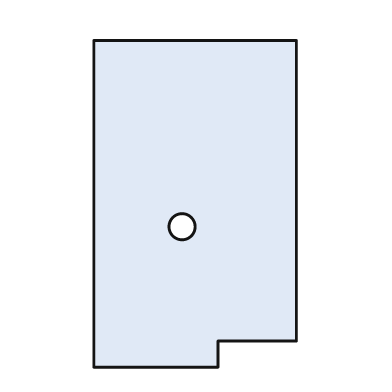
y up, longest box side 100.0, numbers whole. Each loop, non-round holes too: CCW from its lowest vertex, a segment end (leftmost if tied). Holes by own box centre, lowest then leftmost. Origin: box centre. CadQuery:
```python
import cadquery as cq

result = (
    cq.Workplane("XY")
    .moveTo(-31.0, -50.0)
    .lineTo(7.0, -50.0)
    .lineTo(7.0, -42.0)
    .lineTo(31.0, -42.0)
    .lineTo(31.0, 50.0)
    .lineTo(-31.0, 50.0)
    .close()
    .moveTo(-4.0, -7.0)
    .circle(4.0)
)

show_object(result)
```